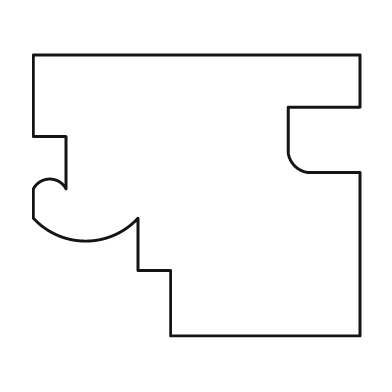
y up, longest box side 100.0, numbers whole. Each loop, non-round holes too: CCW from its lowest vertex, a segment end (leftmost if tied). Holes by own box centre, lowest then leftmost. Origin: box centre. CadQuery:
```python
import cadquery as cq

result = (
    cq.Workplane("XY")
    .moveTo(-8.0, -43.0)
    .lineTo(50.0, -43.0)
    .lineTo(50.0, 7.0)
    .lineTo(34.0, 7.0)
    .threePointArc((30.0, 9.0), (28.0, 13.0))
    .lineTo(28.0, 27.0)
    .lineTo(50.0, 27.0)
    .lineTo(50.0, 43.0)
    .lineTo(-50.0, 43.0)
    .lineTo(-50.0, 18.0)
    .lineTo(-40.0, 18.0)
    .lineTo(-40.0, 2.0)
    .threePointArc((-45.0, 5.0), (-50.0, 2.0))
    .lineTo(-50.0, -7.0)
    .threePointArc((-34.0, -14.0), (-18.0, -7.0))
    .lineTo(-18.0, -23.0)
    .lineTo(-8.0, -23.0)
    .close()
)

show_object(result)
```